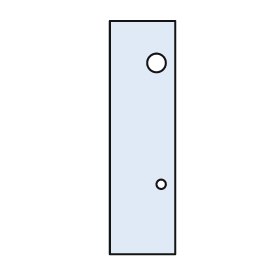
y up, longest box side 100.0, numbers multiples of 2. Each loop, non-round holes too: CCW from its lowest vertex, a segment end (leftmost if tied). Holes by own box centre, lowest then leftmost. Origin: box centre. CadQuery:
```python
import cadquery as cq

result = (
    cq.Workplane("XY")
    .moveTo(-14.0, -50.0)
    .lineTo(14.0, -50.0)
    .lineTo(14.0, 50.0)
    .lineTo(-14.0, 50.0)
    .close()
    .moveTo(8.0, -20.0)
    .circle(2.0)
    .moveTo(6.0, 32.0)
    .circle(4.0)
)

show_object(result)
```